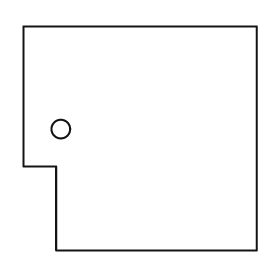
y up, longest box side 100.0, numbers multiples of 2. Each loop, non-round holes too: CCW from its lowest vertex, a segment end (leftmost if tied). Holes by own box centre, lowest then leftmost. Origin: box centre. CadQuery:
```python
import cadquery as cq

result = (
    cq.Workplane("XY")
    .moveTo(-36.0, -48.0)
    .lineTo(50.0, -48.0)
    .lineTo(50.0, 48.0)
    .lineTo(-50.0, 48.0)
    .lineTo(-50.0, -12.0)
    .lineTo(-36.0, -12.0)
    .close()
    .moveTo(-34.0, 4.0)
    .circle(4.0)
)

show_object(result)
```